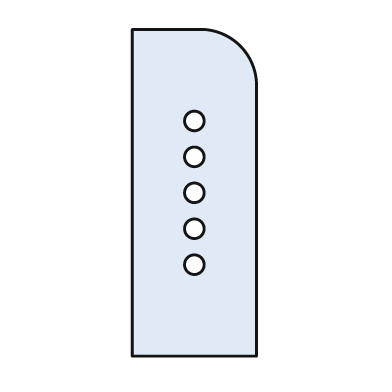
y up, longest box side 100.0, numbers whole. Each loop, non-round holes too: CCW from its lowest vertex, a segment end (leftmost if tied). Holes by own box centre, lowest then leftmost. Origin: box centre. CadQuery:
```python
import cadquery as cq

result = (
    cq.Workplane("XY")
    .moveTo(-19.0, -50.0)
    .lineTo(19.0, -50.0)
    .lineTo(19.0, 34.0)
    .threePointArc((14.0, 45.0), (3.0, 50.0))
    .lineTo(-19.0, 50.0)
    .close()
    .moveTo(0.0, -22.0)
    .circle(3.0)
    .moveTo(0.0, -11.0)
    .circle(3.0)
    .moveTo(0.0, 0.0)
    .circle(3.0)
    .moveTo(0.0, 11.0)
    .circle(3.0)
    .moveTo(0.0, 22.0)
    .circle(3.0)
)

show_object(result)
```